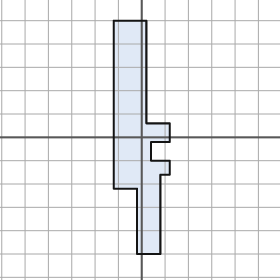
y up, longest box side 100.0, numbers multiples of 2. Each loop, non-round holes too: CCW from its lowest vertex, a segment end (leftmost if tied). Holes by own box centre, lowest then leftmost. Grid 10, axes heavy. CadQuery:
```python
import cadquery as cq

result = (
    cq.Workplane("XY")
    .moveTo(-2.0, -50.0)
    .lineTo(8.0, -50.0)
    .lineTo(8.0, -16.0)
    .lineTo(12.0, -16.0)
    .lineTo(12.0, -10.0)
    .lineTo(4.0, -10.0)
    .lineTo(4.0, -2.0)
    .lineTo(12.0, -2.0)
    .lineTo(12.0, 6.0)
    .lineTo(2.0, 6.0)
    .lineTo(2.0, 50.0)
    .lineTo(-12.0, 50.0)
    .lineTo(-12.0, -22.0)
    .lineTo(-2.0, -22.0)
    .close()
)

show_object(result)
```